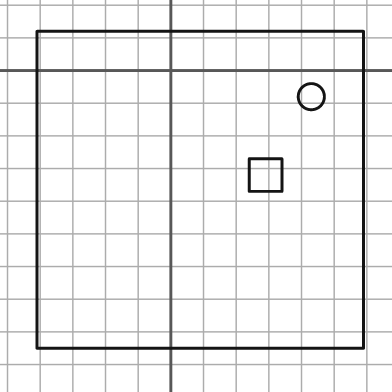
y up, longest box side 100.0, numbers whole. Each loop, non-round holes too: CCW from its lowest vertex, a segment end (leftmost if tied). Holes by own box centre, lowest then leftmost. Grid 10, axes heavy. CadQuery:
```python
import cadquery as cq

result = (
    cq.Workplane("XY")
    .moveTo(-41.0, -85.0)
    .lineTo(59.0, -85.0)
    .lineTo(59.0, 12.0)
    .lineTo(-41.0, 12.0)
    .close()
    .moveTo(24.0, -37.0)
    .lineTo(34.0, -37.0)
    .lineTo(34.0, -27.0)
    .lineTo(24.0, -27.0)
    .close()
    .moveTo(43.0, -8.0)
    .circle(4.0)
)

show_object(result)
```